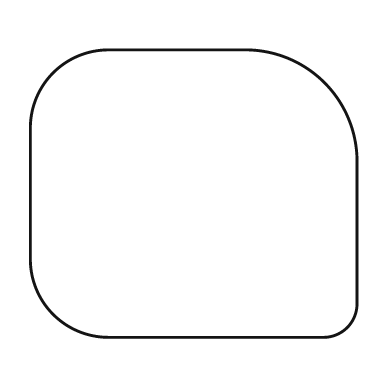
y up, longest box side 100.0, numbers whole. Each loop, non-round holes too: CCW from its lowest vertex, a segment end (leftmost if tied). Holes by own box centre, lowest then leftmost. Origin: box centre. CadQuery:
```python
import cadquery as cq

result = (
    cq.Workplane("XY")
    .moveTo(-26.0, -44.0)
    .lineTo(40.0, -44.0)
    .threePointArc((47.0, -41.0), (50.0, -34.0))
    .lineTo(50.0, 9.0)
    .threePointArc((40.0, 34.0), (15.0, 44.0))
    .lineTo(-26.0, 44.0)
    .threePointArc((-43.0, 37.0), (-50.0, 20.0))
    .lineTo(-50.0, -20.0)
    .threePointArc((-43.0, -37.0), (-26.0, -44.0))
    .close()
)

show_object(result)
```